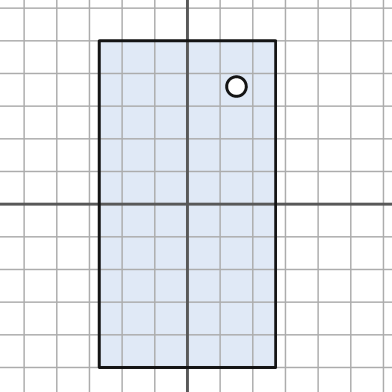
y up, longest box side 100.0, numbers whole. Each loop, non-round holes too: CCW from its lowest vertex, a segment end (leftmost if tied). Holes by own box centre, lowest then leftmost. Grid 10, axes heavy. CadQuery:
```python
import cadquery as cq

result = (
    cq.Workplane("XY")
    .moveTo(-27.0, -50.0)
    .lineTo(27.0, -50.0)
    .lineTo(27.0, 50.0)
    .lineTo(-27.0, 50.0)
    .close()
    .moveTo(15.0, 36.0)
    .circle(3.0)
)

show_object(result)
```